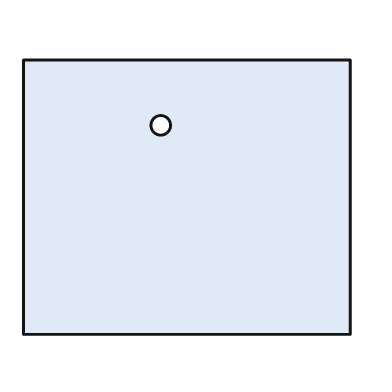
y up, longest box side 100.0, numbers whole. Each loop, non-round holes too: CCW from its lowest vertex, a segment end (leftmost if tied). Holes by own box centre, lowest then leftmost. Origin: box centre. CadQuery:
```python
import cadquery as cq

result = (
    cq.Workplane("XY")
    .moveTo(-50.0, -42.0)
    .lineTo(50.0, -42.0)
    .lineTo(50.0, 42.0)
    .lineTo(-50.0, 42.0)
    .close()
    .moveTo(-8.0, 22.0)
    .circle(3.0)
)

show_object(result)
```